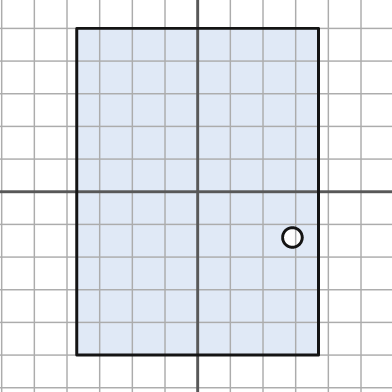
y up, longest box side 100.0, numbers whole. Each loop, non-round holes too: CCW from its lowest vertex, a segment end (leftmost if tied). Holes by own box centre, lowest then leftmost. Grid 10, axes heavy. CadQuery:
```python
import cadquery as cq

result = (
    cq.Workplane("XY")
    .moveTo(-37.0, -50.0)
    .lineTo(37.0, -50.0)
    .lineTo(37.0, 50.0)
    .lineTo(-37.0, 50.0)
    .close()
    .moveTo(29.0, -14.0)
    .circle(3.0)
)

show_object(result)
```